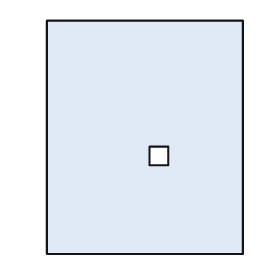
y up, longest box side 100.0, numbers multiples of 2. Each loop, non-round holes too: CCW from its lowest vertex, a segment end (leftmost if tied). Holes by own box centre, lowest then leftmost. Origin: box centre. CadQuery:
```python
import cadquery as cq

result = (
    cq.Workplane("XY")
    .moveTo(-42.0, -50.0)
    .lineTo(42.0, -50.0)
    .lineTo(42.0, 50.0)
    .lineTo(-42.0, 50.0)
    .close()
    .moveTo(2.0, -12.0)
    .lineTo(10.0, -12.0)
    .lineTo(10.0, -4.0)
    .lineTo(2.0, -4.0)
    .close()
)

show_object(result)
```